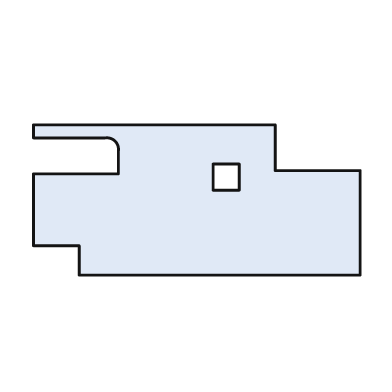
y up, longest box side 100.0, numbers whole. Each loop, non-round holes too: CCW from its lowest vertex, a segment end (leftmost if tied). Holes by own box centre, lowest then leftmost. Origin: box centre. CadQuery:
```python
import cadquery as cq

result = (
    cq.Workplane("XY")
    .moveTo(-36.0, -23.0)
    .lineTo(50.0, -23.0)
    .lineTo(50.0, 9.0)
    .lineTo(24.0, 9.0)
    .lineTo(24.0, 23.0)
    .lineTo(-50.0, 23.0)
    .lineTo(-50.0, 19.0)
    .lineTo(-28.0, 19.0)
    .threePointArc((-25.0, 18.0), (-24.0, 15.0))
    .lineTo(-24.0, 8.0)
    .lineTo(-50.0, 8.0)
    .lineTo(-50.0, -14.0)
    .lineTo(-36.0, -14.0)
    .close()
    .moveTo(5.0, 3.0)
    .lineTo(13.0, 3.0)
    .lineTo(13.0, 11.0)
    .lineTo(5.0, 11.0)
    .close()
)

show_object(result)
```